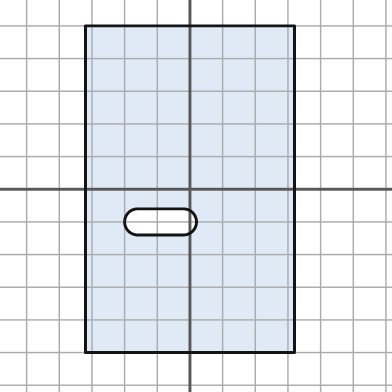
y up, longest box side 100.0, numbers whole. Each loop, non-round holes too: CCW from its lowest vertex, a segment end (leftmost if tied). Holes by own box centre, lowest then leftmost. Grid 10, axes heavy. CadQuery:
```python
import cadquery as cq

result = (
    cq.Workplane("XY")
    .moveTo(-32.0, -50.0)
    .lineTo(32.0, -50.0)
    .lineTo(32.0, 50.0)
    .lineTo(-32.0, 50.0)
    .close()
    .moveTo(-16.0, -14.0)
    .lineTo(-2.0, -14.0)
    .threePointArc((2.0, -10.0), (-2.0, -6.0))
    .lineTo(-16.0, -6.0)
    .threePointArc((-20.0, -10.0), (-16.0, -14.0))
    .close()
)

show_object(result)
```